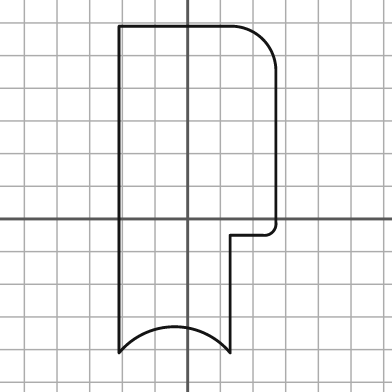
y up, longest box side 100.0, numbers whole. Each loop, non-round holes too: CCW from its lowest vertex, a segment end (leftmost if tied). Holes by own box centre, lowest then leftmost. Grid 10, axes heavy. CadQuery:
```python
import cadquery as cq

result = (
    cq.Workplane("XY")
    .moveTo(-21.0, -41.0)
    .threePointArc((-4.0, -33.0), (13.0, -41.0))
    .lineTo(13.0, -5.0)
    .lineTo(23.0, -5.0)
    .threePointArc((26.0, -4.0), (27.0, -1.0))
    .lineTo(27.0, 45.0)
    .threePointArc((23.0, 55.0), (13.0, 59.0))
    .lineTo(-21.0, 59.0)
    .close()
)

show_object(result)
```